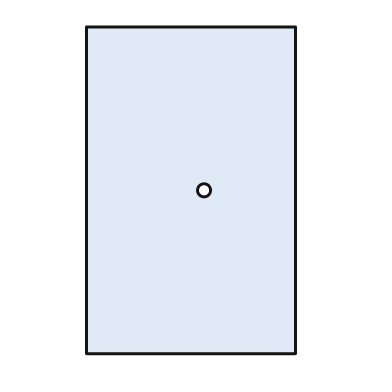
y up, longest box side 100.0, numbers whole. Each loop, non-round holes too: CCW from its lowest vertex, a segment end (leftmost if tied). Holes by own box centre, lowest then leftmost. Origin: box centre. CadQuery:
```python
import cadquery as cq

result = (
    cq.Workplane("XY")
    .moveTo(-32.0, -50.0)
    .lineTo(32.0, -50.0)
    .lineTo(32.0, 50.0)
    .lineTo(-32.0, 50.0)
    .close()
    .moveTo(4.0, 0.0)
    .circle(2.0)
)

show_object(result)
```